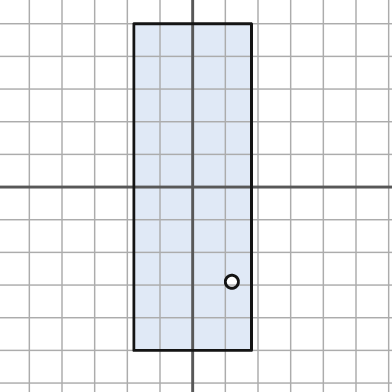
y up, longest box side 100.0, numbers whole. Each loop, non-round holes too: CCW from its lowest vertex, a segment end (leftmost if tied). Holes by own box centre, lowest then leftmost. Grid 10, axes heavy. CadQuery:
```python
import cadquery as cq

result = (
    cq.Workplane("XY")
    .moveTo(-18.0, -50.0)
    .lineTo(18.0, -50.0)
    .lineTo(18.0, 50.0)
    .lineTo(-18.0, 50.0)
    .close()
    .moveTo(12.0, -29.0)
    .circle(2.0)
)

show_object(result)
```